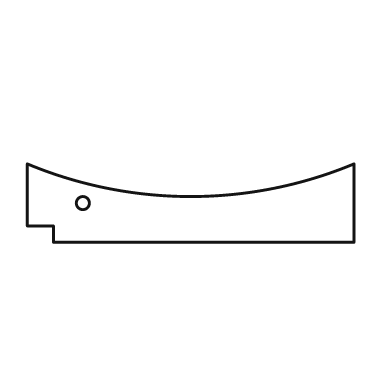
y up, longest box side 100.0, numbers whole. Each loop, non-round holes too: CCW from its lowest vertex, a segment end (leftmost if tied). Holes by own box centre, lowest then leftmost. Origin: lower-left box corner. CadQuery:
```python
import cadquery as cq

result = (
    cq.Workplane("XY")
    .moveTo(8.0, 0.0)
    .lineTo(100.0, 0.0)
    .lineTo(100.0, 24.0)
    .threePointArc((50.0, 14.0), (0.0, 24.0))
    .lineTo(0.0, 5.0)
    .lineTo(8.0, 5.0)
    .close()
    .moveTo(17.0, 12.0)
    .circle(2.0)
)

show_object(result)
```